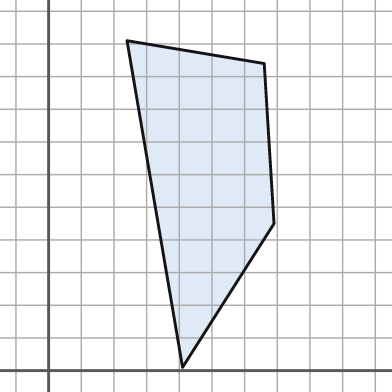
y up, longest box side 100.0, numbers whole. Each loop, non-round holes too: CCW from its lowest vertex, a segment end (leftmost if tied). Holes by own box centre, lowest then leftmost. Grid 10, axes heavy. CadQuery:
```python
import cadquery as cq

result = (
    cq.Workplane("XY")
    .moveTo(41.0, 1.0)
    .lineTo(69.0, 45.0)
    .lineTo(66.0, 94.0)
    .lineTo(24.0, 101.0)
    .close()
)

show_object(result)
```